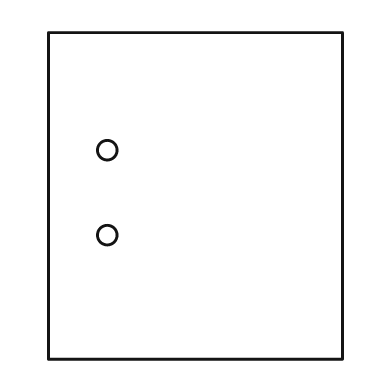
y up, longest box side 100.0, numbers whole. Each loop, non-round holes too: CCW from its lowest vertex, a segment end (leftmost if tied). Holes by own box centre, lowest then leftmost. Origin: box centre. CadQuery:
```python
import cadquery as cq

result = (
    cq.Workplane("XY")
    .moveTo(-45.0, -50.0)
    .lineTo(45.0, -50.0)
    .lineTo(45.0, 50.0)
    .lineTo(-45.0, 50.0)
    .close()
    .moveTo(-27.0, -12.0)
    .circle(3.0)
    .moveTo(-27.0, 14.0)
    .circle(3.0)
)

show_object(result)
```